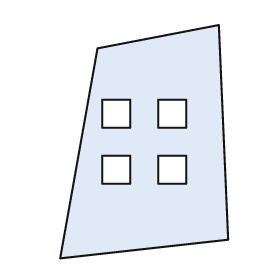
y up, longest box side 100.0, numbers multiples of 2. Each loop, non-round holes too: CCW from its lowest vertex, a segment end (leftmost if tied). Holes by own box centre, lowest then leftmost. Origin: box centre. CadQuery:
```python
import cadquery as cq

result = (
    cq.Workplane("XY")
    .moveTo(-36.0, -50.0)
    .lineTo(36.0, -42.0)
    .lineTo(32.0, 50.0)
    .lineTo(-20.0, 40.0)
    .close()
    .moveTo(-18.0, -18.0)
    .lineTo(-6.0, -18.0)
    .lineTo(-6.0, -6.0)
    .lineTo(-18.0, -6.0)
    .close()
    .moveTo(6.0, -18.0)
    .lineTo(18.0, -18.0)
    .lineTo(18.0, -6.0)
    .lineTo(6.0, -6.0)
    .close()
    .moveTo(-18.0, 6.0)
    .lineTo(-6.0, 6.0)
    .lineTo(-6.0, 18.0)
    .lineTo(-18.0, 18.0)
    .close()
    .moveTo(6.0, 6.0)
    .lineTo(18.0, 6.0)
    .lineTo(18.0, 18.0)
    .lineTo(6.0, 18.0)
    .close()
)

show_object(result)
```